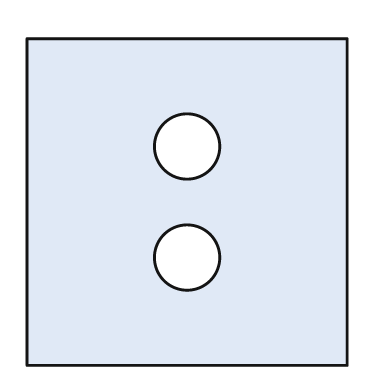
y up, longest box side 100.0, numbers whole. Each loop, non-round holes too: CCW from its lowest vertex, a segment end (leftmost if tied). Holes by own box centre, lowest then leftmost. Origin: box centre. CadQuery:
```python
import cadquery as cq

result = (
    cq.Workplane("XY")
    .moveTo(-49.0, -50.0)
    .lineTo(49.0, -50.0)
    .lineTo(49.0, 50.0)
    .lineTo(-49.0, 50.0)
    .close()
    .moveTo(0.0, -17.0)
    .circle(10.0)
    .moveTo(0.0, 17.0)
    .circle(10.0)
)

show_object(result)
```